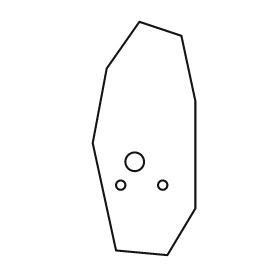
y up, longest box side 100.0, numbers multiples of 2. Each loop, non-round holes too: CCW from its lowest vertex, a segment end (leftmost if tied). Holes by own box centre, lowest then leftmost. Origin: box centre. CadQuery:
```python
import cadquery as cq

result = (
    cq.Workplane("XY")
    .moveTo(10.0, -50.0)
    .lineTo(22.0, -30.0)
    .lineTo(22.0, 16.0)
    .lineTo(16.0, 44.0)
    .lineTo(-2.0, 50.0)
    .lineTo(-16.0, 30.0)
    .lineTo(-22.0, -2.0)
    .lineTo(-12.0, -48.0)
    .close()
    .moveTo(-10.0, -20.0)
    .circle(2.0)
    .moveTo(8.0, -20.0)
    .circle(2.0)
    .moveTo(-4.0, -10.0)
    .circle(4.0)
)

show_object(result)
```